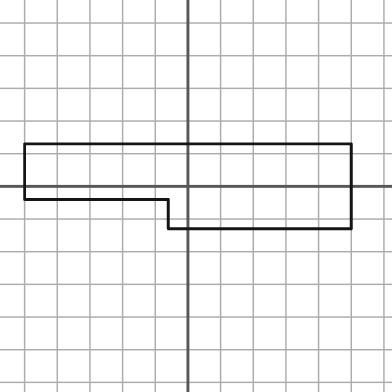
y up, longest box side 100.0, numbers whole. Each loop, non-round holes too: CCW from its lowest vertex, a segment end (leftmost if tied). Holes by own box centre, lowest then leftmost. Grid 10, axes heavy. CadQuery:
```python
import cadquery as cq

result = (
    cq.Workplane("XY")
    .moveTo(-6.0, -13.0)
    .lineTo(50.0, -13.0)
    .lineTo(50.0, 13.0)
    .lineTo(-50.0, 13.0)
    .lineTo(-50.0, -4.0)
    .lineTo(-6.0, -4.0)
    .close()
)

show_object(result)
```